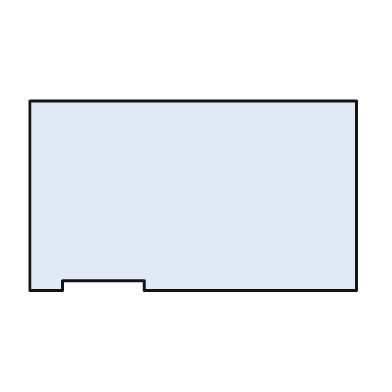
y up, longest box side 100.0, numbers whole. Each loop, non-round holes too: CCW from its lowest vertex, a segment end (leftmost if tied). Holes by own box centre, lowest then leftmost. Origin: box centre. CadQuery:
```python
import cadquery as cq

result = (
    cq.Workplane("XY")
    .moveTo(-50.0, -29.0)
    .lineTo(-40.0, -29.0)
    .lineTo(-40.0, -26.0)
    .lineTo(-15.0, -26.0)
    .lineTo(-15.0, -29.0)
    .lineTo(50.0, -29.0)
    .lineTo(50.0, 29.0)
    .lineTo(-50.0, 29.0)
    .close()
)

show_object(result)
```